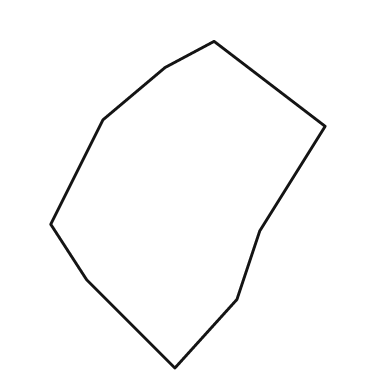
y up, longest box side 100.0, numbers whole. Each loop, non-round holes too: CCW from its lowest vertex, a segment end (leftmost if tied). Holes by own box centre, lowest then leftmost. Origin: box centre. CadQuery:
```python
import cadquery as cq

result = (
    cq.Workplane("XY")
    .moveTo(-4.0, -50.0)
    .lineTo(15.0, -29.0)
    .lineTo(22.0, -8.0)
    .lineTo(42.0, 24.0)
    .lineTo(8.0, 50.0)
    .lineTo(-7.0, 42.0)
    .lineTo(-26.0, 26.0)
    .lineTo(-42.0, -6.0)
    .lineTo(-31.0, -23.0)
    .close()
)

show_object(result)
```